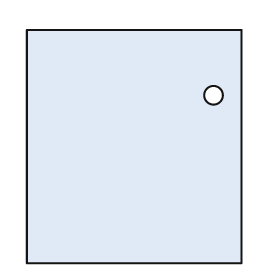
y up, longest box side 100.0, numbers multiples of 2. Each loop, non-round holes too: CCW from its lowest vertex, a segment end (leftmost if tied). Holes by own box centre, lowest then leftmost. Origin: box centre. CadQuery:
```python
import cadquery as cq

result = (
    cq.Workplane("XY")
    .moveTo(-46.0, -50.0)
    .lineTo(46.0, -50.0)
    .lineTo(46.0, 50.0)
    .lineTo(-46.0, 50.0)
    .close()
    .moveTo(34.0, 22.0)
    .circle(4.0)
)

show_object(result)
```